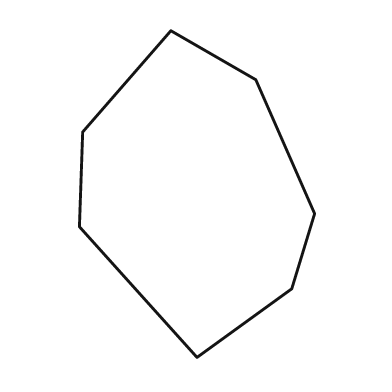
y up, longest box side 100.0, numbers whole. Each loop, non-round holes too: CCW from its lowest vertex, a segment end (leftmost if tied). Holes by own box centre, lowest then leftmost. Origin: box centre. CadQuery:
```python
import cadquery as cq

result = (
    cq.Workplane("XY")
    .moveTo(0.0, -50.0)
    .lineTo(29.0, -29.0)
    .lineTo(36.0, -6.0)
    .lineTo(18.0, 35.0)
    .lineTo(-8.0, 50.0)
    .lineTo(-35.0, 19.0)
    .lineTo(-36.0, -10.0)
    .close()
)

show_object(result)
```